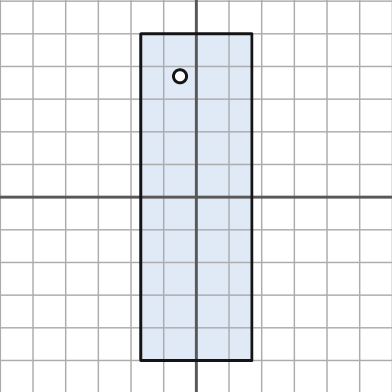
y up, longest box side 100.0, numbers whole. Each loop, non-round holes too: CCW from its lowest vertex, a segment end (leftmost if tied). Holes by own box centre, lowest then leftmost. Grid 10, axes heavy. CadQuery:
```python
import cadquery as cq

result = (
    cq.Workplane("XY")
    .moveTo(-17.0, -50.0)
    .lineTo(17.0, -50.0)
    .lineTo(17.0, 50.0)
    .lineTo(-17.0, 50.0)
    .close()
    .moveTo(-5.0, 37.0)
    .circle(2.0)
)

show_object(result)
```